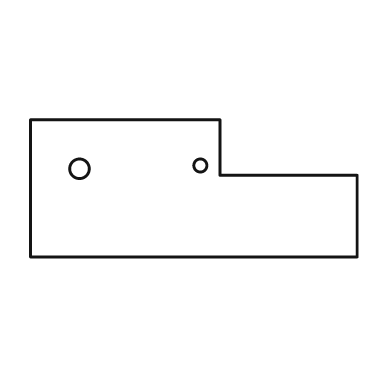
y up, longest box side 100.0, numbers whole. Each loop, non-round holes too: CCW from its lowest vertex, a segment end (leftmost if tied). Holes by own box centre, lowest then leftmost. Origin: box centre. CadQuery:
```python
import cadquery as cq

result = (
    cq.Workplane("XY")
    .moveTo(-50.0, -21.0)
    .lineTo(50.0, -21.0)
    .lineTo(50.0, 4.0)
    .lineTo(8.0, 4.0)
    .lineTo(8.0, 21.0)
    .lineTo(-50.0, 21.0)
    .close()
    .moveTo(-35.0, 6.0)
    .circle(3.0)
    .moveTo(2.0, 7.0)
    .circle(2.0)
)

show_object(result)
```